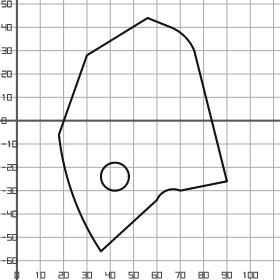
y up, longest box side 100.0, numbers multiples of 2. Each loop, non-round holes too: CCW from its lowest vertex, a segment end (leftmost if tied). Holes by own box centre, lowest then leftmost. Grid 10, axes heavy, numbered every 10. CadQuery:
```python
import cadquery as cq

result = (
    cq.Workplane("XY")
    .moveTo(36.0, -56.0)
    .lineTo(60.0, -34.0)
    .threePointArc((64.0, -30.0), (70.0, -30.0))
    .lineTo(90.0, -26.0)
    .lineTo(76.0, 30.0)
    .threePointArc((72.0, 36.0), (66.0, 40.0))
    .lineTo(56.0, 44.0)
    .lineTo(30.0, 28.0)
    .lineTo(18.0, -6.0)
    .threePointArc((24.0, -32.0), (36.0, -56.0))
    .close()
    .moveTo(42.0, -24.0)
    .circle(6.0)
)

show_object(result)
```